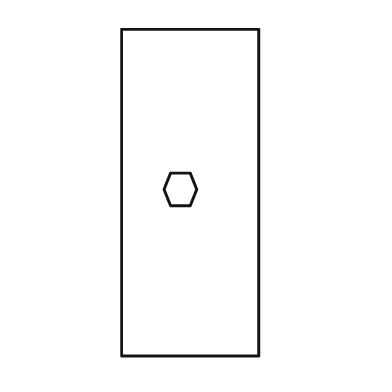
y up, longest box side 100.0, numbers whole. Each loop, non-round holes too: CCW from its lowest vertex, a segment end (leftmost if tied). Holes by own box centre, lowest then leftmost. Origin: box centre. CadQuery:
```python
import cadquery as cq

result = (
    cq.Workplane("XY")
    .moveTo(-21.0, -50.0)
    .lineTo(21.0, -50.0)
    .lineTo(21.0, 50.0)
    .lineTo(-21.0, 50.0)
    .close()
    .moveTo(-6.0, -4.0)
    .lineTo(0.0, -4.0)
    .lineTo(2.0, 1.0)
    .lineTo(0.0, 6.0)
    .lineTo(-6.0, 6.0)
    .lineTo(-8.0, 1.0)
    .close()
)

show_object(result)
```